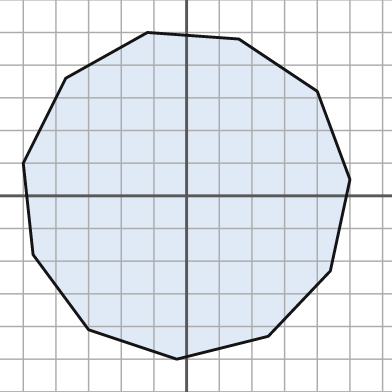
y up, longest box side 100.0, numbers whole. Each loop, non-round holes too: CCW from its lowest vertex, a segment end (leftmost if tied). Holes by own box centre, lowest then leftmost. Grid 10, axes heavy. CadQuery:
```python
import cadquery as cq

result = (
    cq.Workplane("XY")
    .moveTo(-3.0, -50.0)
    .lineTo(25.0, -43.0)
    .lineTo(44.0, -23.0)
    .lineTo(50.0, 5.0)
    .lineTo(40.0, 32.0)
    .lineTo(16.0, 48.0)
    .lineTo(-12.0, 50.0)
    .lineTo(-37.0, 36.0)
    .lineTo(-50.0, 10.0)
    .lineTo(-47.0, -18.0)
    .lineTo(-30.0, -41.0)
    .close()
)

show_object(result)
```